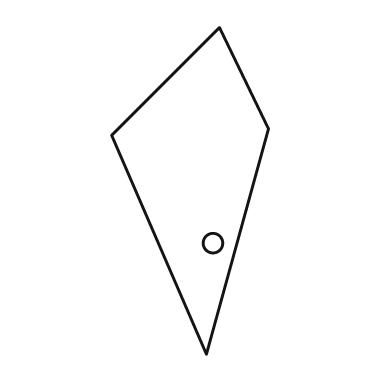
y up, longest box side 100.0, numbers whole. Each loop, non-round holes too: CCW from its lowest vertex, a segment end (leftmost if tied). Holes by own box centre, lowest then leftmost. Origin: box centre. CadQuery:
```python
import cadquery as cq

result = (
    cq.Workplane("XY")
    .moveTo(5.0, -50.0)
    .lineTo(24.0, 19.0)
    .lineTo(9.0, 50.0)
    .lineTo(-24.0, 17.0)
    .close()
    .moveTo(7.0, -16.0)
    .circle(3.0)
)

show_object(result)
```